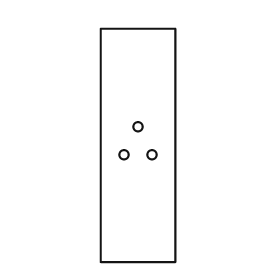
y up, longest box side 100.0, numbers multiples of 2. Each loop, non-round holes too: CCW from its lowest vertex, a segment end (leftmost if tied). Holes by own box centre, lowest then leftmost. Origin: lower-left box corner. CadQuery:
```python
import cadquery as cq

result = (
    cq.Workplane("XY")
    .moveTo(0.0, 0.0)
    .lineTo(32.0, 0.0)
    .lineTo(32.0, 100.0)
    .lineTo(0.0, 100.0)
    .close()
    .moveTo(10.0, 46.0)
    .circle(2.0)
    .moveTo(22.0, 46.0)
    .circle(2.0)
    .moveTo(16.0, 58.0)
    .circle(2.0)
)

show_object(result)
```